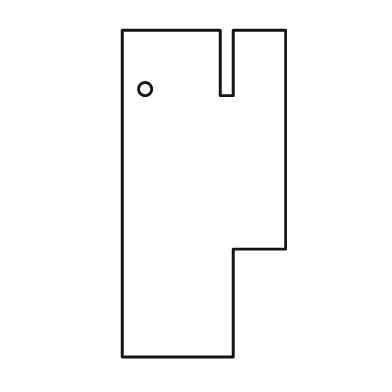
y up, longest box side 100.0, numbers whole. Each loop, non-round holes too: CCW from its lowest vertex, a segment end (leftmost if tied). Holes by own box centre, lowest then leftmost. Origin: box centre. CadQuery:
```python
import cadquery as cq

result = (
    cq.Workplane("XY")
    .moveTo(-25.0, -50.0)
    .lineTo(9.0, -50.0)
    .lineTo(9.0, -17.0)
    .lineTo(25.0, -17.0)
    .lineTo(25.0, 50.0)
    .lineTo(9.0, 50.0)
    .lineTo(9.0, 30.0)
    .lineTo(5.0, 30.0)
    .lineTo(5.0, 50.0)
    .lineTo(-25.0, 50.0)
    .close()
    .moveTo(-18.0, 32.0)
    .circle(2.0)
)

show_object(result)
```